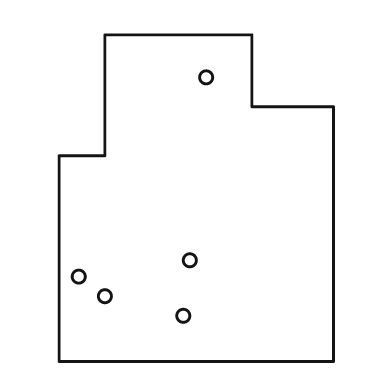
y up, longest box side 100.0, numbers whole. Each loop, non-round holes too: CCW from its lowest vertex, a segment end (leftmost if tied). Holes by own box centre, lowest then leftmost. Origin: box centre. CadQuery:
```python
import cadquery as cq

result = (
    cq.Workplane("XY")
    .moveTo(-42.0, -50.0)
    .lineTo(42.0, -50.0)
    .lineTo(42.0, 28.0)
    .lineTo(17.0, 28.0)
    .lineTo(17.0, 50.0)
    .lineTo(-28.0, 50.0)
    .lineTo(-28.0, 13.0)
    .lineTo(-42.0, 13.0)
    .close()
    .moveTo(-4.0, -36.0)
    .circle(2.0)
    .moveTo(-28.0, -30.0)
    .circle(2.0)
    .moveTo(-36.0, -24.0)
    .circle(2.0)
    .moveTo(-2.0, -19.0)
    .circle(2.0)
    .moveTo(3.0, 37.0)
    .circle(2.0)
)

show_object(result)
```